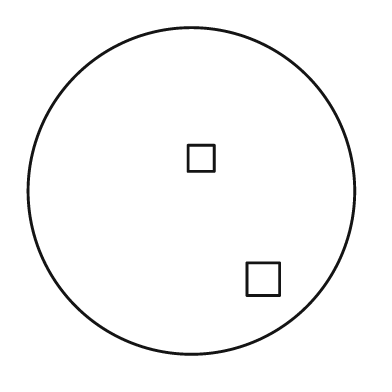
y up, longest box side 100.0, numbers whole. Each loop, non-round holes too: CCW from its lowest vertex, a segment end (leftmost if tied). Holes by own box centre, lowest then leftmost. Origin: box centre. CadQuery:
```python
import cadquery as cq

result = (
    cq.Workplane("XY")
    .moveTo(0.0, 0.0)
    .circle(50.0)
    .moveTo(17.0, -32.0)
    .lineTo(27.0, -32.0)
    .lineTo(27.0, -22.0)
    .lineTo(17.0, -22.0)
    .close()
    .moveTo(-1.0, 6.0)
    .lineTo(7.0, 6.0)
    .lineTo(7.0, 14.0)
    .lineTo(-1.0, 14.0)
    .close()
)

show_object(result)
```